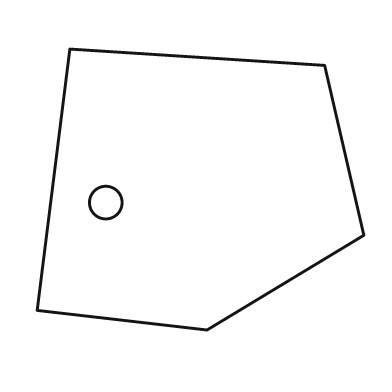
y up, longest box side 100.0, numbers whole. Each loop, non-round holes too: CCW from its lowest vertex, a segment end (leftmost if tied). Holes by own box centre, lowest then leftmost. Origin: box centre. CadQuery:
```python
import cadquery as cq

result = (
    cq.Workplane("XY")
    .moveTo(2.0, -43.0)
    .lineTo(50.0, -14.0)
    .lineTo(38.0, 38.0)
    .lineTo(-40.0, 43.0)
    .lineTo(-50.0, -37.0)
    .close()
    .moveTo(-29.0, -4.0)
    .circle(5.0)
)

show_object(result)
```